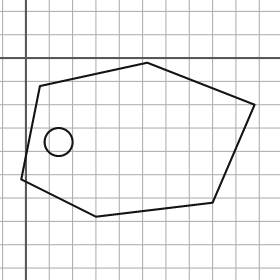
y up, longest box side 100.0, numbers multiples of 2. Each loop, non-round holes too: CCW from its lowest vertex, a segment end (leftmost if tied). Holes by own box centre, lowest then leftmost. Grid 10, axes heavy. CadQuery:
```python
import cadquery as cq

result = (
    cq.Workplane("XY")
    .moveTo(30.0, -68.0)
    .lineTo(80.0, -62.0)
    .lineTo(98.0, -20.0)
    .lineTo(52.0, -2.0)
    .lineTo(6.0, -12.0)
    .lineTo(-2.0, -52.0)
    .close()
    .moveTo(14.0, -36.0)
    .circle(6.0)
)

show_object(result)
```